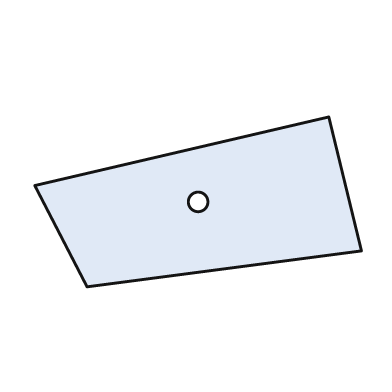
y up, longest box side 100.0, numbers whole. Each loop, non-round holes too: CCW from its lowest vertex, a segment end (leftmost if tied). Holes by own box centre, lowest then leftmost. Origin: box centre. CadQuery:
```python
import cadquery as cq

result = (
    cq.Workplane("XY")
    .moveTo(-34.0, -26.0)
    .lineTo(50.0, -15.0)
    .lineTo(40.0, 26.0)
    .lineTo(-50.0, 5.0)
    .close()
    .moveTo(0.0, 0.0)
    .circle(3.0)
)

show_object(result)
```